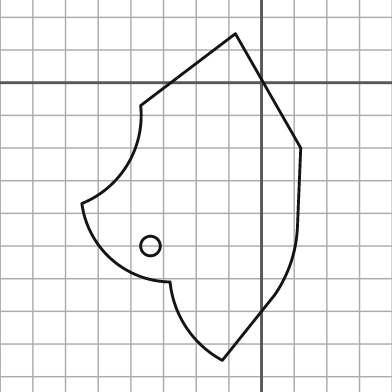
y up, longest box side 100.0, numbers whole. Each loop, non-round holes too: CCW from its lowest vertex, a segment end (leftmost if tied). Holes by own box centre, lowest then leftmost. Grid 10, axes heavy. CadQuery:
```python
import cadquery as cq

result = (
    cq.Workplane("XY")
    .moveTo(-12.0, -85.0)
    .lineTo(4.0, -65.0)
    .threePointArc((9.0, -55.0), (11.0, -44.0))
    .lineTo(12.0, -20.0)
    .lineTo(-8.0, 15.0)
    .lineTo(-37.0, -7.0)
    .threePointArc((-41.0, -25.0), (-55.0, -37.0))
    .threePointArc((-46.0, -54.0), (-28.0, -61.0))
    .threePointArc((-23.0, -75.0), (-12.0, -85.0))
    .close()
    .moveTo(-34.0, -50.0)
    .circle(3.0)
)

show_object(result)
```